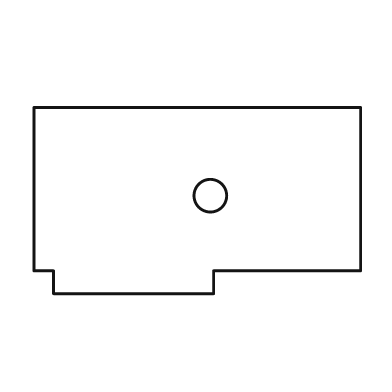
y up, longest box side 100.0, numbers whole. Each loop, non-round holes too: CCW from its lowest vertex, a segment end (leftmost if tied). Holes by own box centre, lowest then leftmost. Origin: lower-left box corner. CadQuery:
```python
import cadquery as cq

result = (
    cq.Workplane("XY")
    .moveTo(6.0, 0.0)
    .lineTo(55.0, 0.0)
    .lineTo(55.0, 7.0)
    .lineTo(100.0, 7.0)
    .lineTo(100.0, 57.0)
    .lineTo(0.0, 57.0)
    .lineTo(0.0, 7.0)
    .lineTo(6.0, 7.0)
    .close()
    .moveTo(54.0, 30.0)
    .circle(5.0)
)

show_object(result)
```